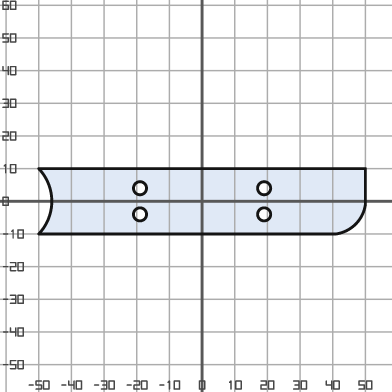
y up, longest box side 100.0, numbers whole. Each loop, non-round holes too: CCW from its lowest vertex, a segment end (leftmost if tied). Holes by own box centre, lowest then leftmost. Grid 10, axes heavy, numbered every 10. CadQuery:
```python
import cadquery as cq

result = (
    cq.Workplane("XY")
    .moveTo(-50.0, -10.0)
    .lineTo(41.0, -10.0)
    .threePointArc((47.0, -7.0), (50.0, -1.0))
    .lineTo(50.0, 10.0)
    .lineTo(-50.0, 10.0)
    .threePointArc((-46.0, 0.0), (-50.0, -10.0))
    .close()
    .moveTo(-19.0, -4.0)
    .circle(2.0)
    .moveTo(19.0, -4.0)
    .circle(2.0)
    .moveTo(-19.0, 4.0)
    .circle(2.0)
    .moveTo(19.0, 4.0)
    .circle(2.0)
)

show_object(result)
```